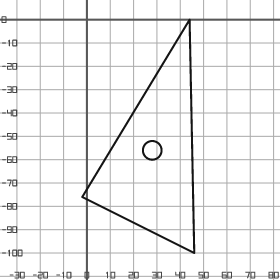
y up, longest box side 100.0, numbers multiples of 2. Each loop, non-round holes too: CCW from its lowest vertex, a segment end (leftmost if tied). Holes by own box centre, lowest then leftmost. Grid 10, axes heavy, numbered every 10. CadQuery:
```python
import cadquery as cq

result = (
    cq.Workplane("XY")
    .moveTo(46.0, -100.0)
    .lineTo(44.0, 0.0)
    .lineTo(-2.0, -76.0)
    .close()
    .moveTo(28.0, -56.0)
    .circle(4.0)
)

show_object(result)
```